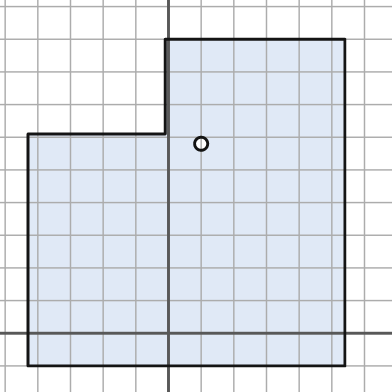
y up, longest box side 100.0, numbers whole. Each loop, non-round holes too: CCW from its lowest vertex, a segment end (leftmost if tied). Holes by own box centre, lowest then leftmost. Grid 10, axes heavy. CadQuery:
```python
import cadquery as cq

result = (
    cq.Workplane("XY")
    .moveTo(-43.0, -10.0)
    .lineTo(54.0, -10.0)
    .lineTo(54.0, 90.0)
    .lineTo(-1.0, 90.0)
    .lineTo(-1.0, 61.0)
    .lineTo(-43.0, 61.0)
    .close()
    .moveTo(10.0, 58.0)
    .circle(2.0)
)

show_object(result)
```